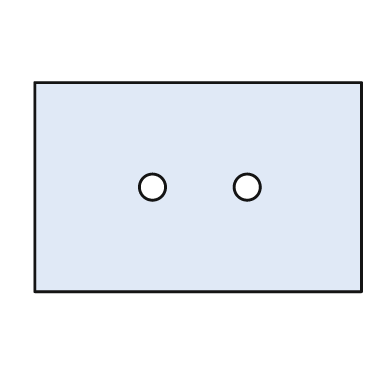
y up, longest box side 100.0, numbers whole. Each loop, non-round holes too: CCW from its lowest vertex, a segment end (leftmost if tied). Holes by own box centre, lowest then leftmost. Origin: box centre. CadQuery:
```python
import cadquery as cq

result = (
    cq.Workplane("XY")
    .moveTo(-50.0, -32.0)
    .lineTo(50.0, -32.0)
    .lineTo(50.0, 32.0)
    .lineTo(-50.0, 32.0)
    .close()
    .moveTo(-14.0, 0.0)
    .circle(4.0)
    .moveTo(15.0, 0.0)
    .circle(4.0)
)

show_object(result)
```